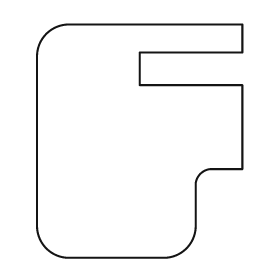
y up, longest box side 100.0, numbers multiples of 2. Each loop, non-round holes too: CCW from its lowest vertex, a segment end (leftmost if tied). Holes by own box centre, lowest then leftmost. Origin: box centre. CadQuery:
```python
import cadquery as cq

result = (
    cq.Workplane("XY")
    .moveTo(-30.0, -50.0)
    .lineTo(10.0, -50.0)
    .threePointArc((20.0, -46.0), (24.0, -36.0))
    .lineTo(24.0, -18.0)
    .threePointArc((26.0, -14.0), (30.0, -12.0))
    .lineTo(44.0, -12.0)
    .lineTo(44.0, 24.0)
    .lineTo(0.0, 24.0)
    .lineTo(0.0, 38.0)
    .lineTo(44.0, 38.0)
    .lineTo(44.0, 50.0)
    .lineTo(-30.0, 50.0)
    .threePointArc((-40.0, 46.0), (-44.0, 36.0))
    .lineTo(-44.0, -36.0)
    .threePointArc((-40.0, -46.0), (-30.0, -50.0))
    .close()
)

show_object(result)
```